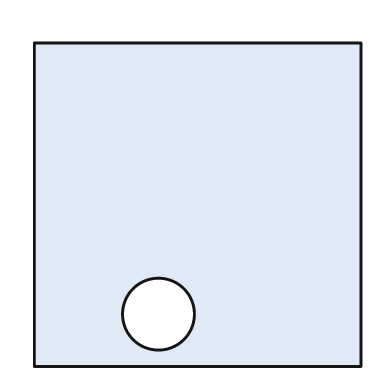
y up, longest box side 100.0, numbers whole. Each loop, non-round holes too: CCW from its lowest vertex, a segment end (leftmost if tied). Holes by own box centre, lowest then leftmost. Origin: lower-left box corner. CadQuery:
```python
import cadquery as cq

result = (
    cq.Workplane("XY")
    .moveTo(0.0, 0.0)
    .lineTo(100.0, 0.0)
    .lineTo(100.0, 99.0)
    .lineTo(0.0, 99.0)
    .close()
    .moveTo(38.0, 16.0)
    .circle(11.0)
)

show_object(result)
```